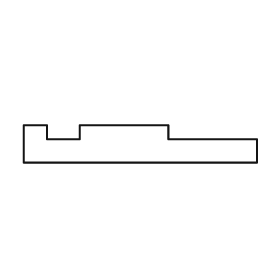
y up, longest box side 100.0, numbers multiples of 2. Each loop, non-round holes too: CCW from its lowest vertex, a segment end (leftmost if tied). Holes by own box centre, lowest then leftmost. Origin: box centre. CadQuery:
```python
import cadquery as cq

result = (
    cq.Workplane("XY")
    .moveTo(-50.0, -8.0)
    .lineTo(50.0, -8.0)
    .lineTo(50.0, 2.0)
    .lineTo(12.0, 2.0)
    .lineTo(12.0, 8.0)
    .lineTo(-26.0, 8.0)
    .lineTo(-26.0, 2.0)
    .lineTo(-40.0, 2.0)
    .lineTo(-40.0, 8.0)
    .lineTo(-50.0, 8.0)
    .close()
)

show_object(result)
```